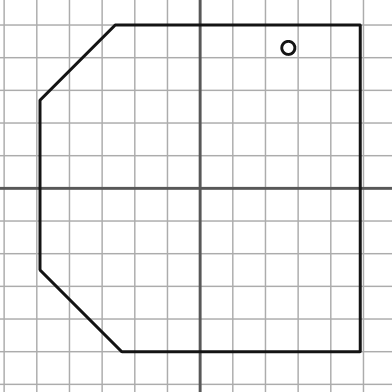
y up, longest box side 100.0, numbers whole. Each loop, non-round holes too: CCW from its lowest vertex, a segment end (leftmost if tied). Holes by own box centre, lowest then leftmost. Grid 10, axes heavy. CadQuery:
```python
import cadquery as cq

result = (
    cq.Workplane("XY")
    .moveTo(-24.0, -50.0)
    .lineTo(49.0, -50.0)
    .lineTo(49.0, 50.0)
    .lineTo(-26.0, 50.0)
    .lineTo(-49.0, 27.0)
    .lineTo(-49.0, -25.0)
    .close()
    .moveTo(27.0, 43.0)
    .circle(2.0)
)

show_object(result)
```